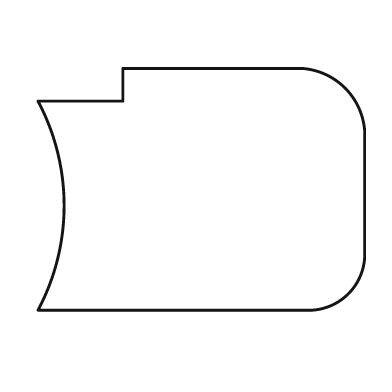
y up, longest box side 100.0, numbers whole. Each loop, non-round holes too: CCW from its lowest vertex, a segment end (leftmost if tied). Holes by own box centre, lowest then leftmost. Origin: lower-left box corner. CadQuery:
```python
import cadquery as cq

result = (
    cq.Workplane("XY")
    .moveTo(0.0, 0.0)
    .lineTo(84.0, 0.0)
    .threePointArc((95.0, 5.0), (100.0, 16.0))
    .lineTo(100.0, 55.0)
    .threePointArc((94.0, 68.0), (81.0, 74.0))
    .lineTo(26.0, 74.0)
    .lineTo(26.0, 64.0)
    .lineTo(0.0, 64.0)
    .threePointArc((8.0, 32.0), (0.0, 0.0))
    .close()
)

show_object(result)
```